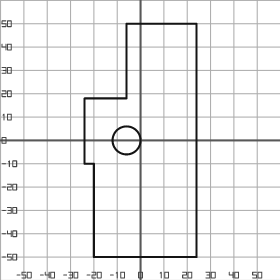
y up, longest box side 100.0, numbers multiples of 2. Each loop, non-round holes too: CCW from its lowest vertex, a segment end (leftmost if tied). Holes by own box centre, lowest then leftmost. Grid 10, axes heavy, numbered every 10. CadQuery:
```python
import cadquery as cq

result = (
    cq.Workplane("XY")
    .moveTo(-20.0, -50.0)
    .lineTo(24.0, -50.0)
    .lineTo(24.0, 50.0)
    .lineTo(-6.0, 50.0)
    .lineTo(-6.0, 18.0)
    .lineTo(-24.0, 18.0)
    .lineTo(-24.0, -10.0)
    .lineTo(-20.0, -10.0)
    .close()
    .moveTo(-6.0, 0.0)
    .circle(6.0)
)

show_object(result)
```